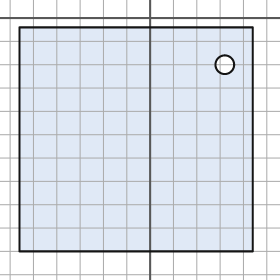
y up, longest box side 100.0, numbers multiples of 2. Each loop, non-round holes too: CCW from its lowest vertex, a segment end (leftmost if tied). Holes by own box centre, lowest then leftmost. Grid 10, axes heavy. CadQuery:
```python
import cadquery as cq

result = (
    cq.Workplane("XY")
    .moveTo(-56.0, -100.0)
    .lineTo(44.0, -100.0)
    .lineTo(44.0, -4.0)
    .lineTo(-56.0, -4.0)
    .close()
    .moveTo(32.0, -20.0)
    .circle(4.0)
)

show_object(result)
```